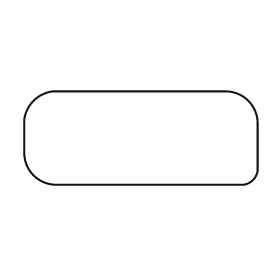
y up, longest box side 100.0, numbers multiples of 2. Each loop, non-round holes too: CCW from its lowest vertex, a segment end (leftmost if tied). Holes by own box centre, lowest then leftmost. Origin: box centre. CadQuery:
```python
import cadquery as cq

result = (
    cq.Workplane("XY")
    .moveTo(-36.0, -20.0)
    .lineTo(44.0, -20.0)
    .threePointArc((48.0, -18.0), (50.0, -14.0))
    .lineTo(50.0, 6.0)
    .threePointArc((46.0, 16.0), (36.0, 20.0))
    .lineTo(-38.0, 20.0)
    .threePointArc((-46.0, 16.0), (-50.0, 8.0))
    .lineTo(-50.0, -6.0)
    .threePointArc((-46.0, -16.0), (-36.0, -20.0))
    .close()
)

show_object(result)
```